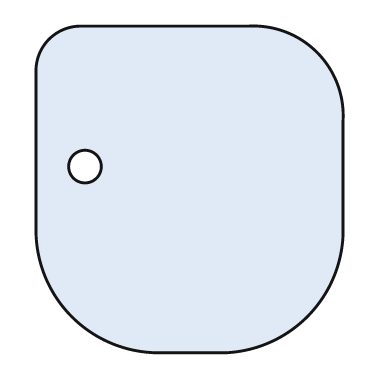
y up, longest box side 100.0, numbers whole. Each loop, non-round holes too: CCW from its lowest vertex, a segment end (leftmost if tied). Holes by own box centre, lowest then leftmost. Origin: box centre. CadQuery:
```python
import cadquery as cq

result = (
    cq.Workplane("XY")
    .moveTo(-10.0, -50.0)
    .lineTo(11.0, -50.0)
    .threePointArc((36.0, -39.0), (47.0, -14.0))
    .lineTo(47.0, 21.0)
    .threePointArc((39.0, 42.0), (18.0, 50.0))
    .lineTo(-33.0, 50.0)
    .threePointArc((-43.0, 46.0), (-47.0, 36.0))
    .lineTo(-47.0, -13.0)
    .threePointArc((-36.0, -39.0), (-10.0, -50.0))
    .close()
    .moveTo(-32.0, 7.0)
    .circle(5.0)
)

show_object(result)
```